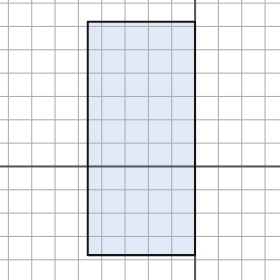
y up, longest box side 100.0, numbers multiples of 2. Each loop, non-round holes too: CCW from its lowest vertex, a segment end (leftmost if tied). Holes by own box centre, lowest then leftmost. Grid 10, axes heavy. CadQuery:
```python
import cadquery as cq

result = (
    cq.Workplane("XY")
    .moveTo(-46.0, -38.0)
    .lineTo(0.0, -38.0)
    .lineTo(0.0, 62.0)
    .lineTo(-46.0, 62.0)
    .close()
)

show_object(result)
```